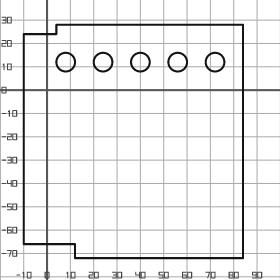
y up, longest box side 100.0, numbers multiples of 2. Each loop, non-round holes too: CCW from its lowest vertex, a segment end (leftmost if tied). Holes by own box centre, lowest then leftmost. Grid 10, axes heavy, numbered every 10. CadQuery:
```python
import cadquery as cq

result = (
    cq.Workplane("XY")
    .moveTo(12.0, -72.0)
    .lineTo(84.0, -72.0)
    .lineTo(84.0, 28.0)
    .lineTo(4.0, 28.0)
    .lineTo(4.0, 24.0)
    .lineTo(-10.0, 24.0)
    .lineTo(-10.0, -66.0)
    .lineTo(12.0, -66.0)
    .close()
    .moveTo(8.0, 12.0)
    .circle(4.0)
    .moveTo(24.0, 12.0)
    .circle(4.0)
    .moveTo(40.0, 12.0)
    .circle(4.0)
    .moveTo(56.0, 12.0)
    .circle(4.0)
    .moveTo(72.0, 12.0)
    .circle(4.0)
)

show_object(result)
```